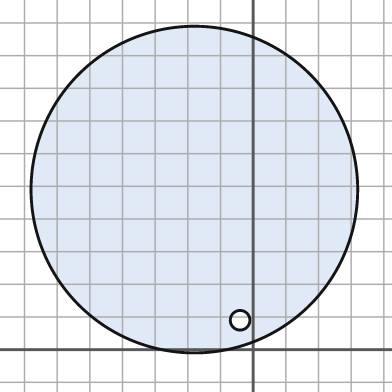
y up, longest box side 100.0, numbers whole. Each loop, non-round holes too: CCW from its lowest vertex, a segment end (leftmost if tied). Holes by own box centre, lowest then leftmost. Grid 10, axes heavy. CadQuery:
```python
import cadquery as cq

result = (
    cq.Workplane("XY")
    .moveTo(-18.0, 49.0)
    .circle(50.0)
    .moveTo(-4.0, 9.0)
    .circle(3.0)
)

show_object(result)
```